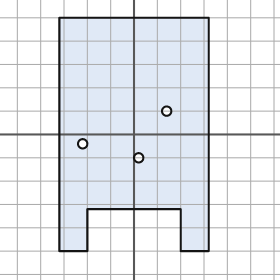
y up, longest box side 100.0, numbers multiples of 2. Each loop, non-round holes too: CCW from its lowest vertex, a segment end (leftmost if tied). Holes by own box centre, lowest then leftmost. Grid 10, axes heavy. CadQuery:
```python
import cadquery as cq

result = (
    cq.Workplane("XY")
    .moveTo(-32.0, -50.0)
    .lineTo(-20.0, -50.0)
    .lineTo(-20.0, -32.0)
    .lineTo(20.0, -32.0)
    .lineTo(20.0, -50.0)
    .lineTo(32.0, -50.0)
    .lineTo(32.0, 50.0)
    .lineTo(-32.0, 50.0)
    .close()
    .moveTo(2.0, -10.0)
    .circle(2.0)
    .moveTo(-22.0, -4.0)
    .circle(2.0)
    .moveTo(14.0, 10.0)
    .circle(2.0)
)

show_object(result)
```